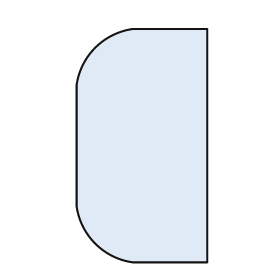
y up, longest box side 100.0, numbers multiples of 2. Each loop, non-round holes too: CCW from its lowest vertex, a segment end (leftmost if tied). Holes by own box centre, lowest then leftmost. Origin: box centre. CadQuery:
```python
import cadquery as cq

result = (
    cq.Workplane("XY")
    .moveTo(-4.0, -50.0)
    .lineTo(28.0, -50.0)
    .lineTo(28.0, 50.0)
    .lineTo(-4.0, 50.0)
    .threePointArc((-20.0, 42.0), (-28.0, 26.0))
    .lineTo(-28.0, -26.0)
    .threePointArc((-20.0, -42.0), (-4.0, -50.0))
    .close()
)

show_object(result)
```